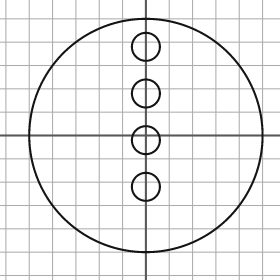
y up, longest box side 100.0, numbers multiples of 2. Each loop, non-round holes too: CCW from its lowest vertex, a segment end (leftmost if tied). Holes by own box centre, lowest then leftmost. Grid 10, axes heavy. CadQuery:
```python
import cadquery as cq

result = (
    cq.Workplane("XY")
    .moveTo(0.0, 0.0)
    .circle(50.0)
    .moveTo(0.0, -22.0)
    .circle(6.0)
    .moveTo(0.0, -2.0)
    .circle(6.0)
    .moveTo(0.0, 18.0)
    .circle(6.0)
    .moveTo(0.0, 38.0)
    .circle(6.0)
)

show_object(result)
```